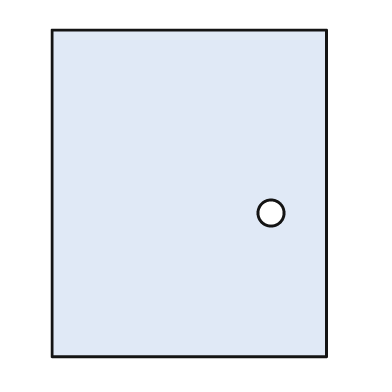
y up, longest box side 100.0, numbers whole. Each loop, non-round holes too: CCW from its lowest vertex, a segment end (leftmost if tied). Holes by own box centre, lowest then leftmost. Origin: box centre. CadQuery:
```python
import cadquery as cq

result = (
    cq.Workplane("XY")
    .moveTo(-42.0, -50.0)
    .lineTo(42.0, -50.0)
    .lineTo(42.0, 50.0)
    .lineTo(-42.0, 50.0)
    .close()
    .moveTo(25.0, -6.0)
    .circle(4.0)
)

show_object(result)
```